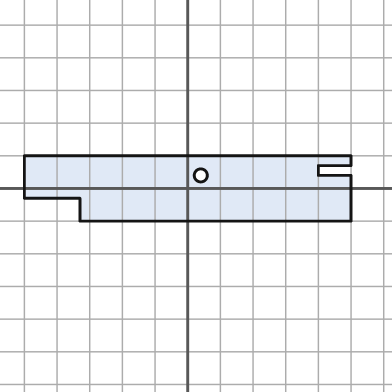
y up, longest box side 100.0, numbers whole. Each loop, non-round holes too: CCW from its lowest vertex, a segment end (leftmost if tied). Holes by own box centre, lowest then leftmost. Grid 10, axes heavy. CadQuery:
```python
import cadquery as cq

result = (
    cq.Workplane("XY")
    .moveTo(-33.0, -10.0)
    .lineTo(50.0, -10.0)
    .lineTo(50.0, 4.0)
    .lineTo(40.0, 4.0)
    .lineTo(40.0, 7.0)
    .lineTo(50.0, 7.0)
    .lineTo(50.0, 10.0)
    .lineTo(-50.0, 10.0)
    .lineTo(-50.0, -3.0)
    .lineTo(-33.0, -3.0)
    .close()
    .moveTo(4.0, 4.0)
    .circle(2.0)
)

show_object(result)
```